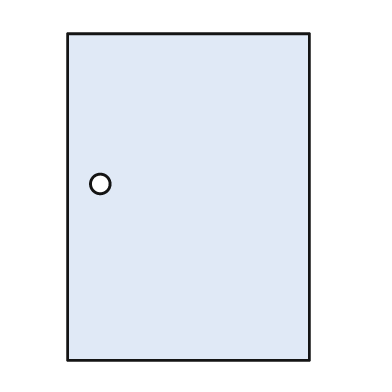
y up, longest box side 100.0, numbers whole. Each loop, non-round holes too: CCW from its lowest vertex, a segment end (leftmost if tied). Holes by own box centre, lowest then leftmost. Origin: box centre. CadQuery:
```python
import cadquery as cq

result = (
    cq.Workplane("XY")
    .moveTo(-37.0, -50.0)
    .lineTo(37.0, -50.0)
    .lineTo(37.0, 50.0)
    .lineTo(-37.0, 50.0)
    .close()
    .moveTo(-27.0, 4.0)
    .circle(3.0)
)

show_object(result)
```